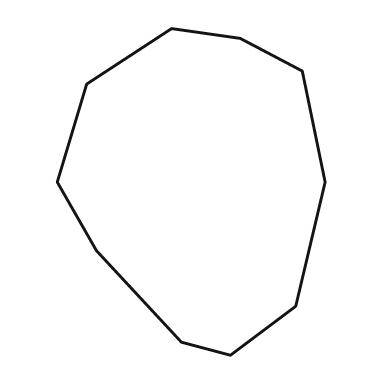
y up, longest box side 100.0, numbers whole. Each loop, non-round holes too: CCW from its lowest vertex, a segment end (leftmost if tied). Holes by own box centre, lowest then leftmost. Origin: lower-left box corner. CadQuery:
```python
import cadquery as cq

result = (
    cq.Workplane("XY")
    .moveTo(53.0, 0.0)
    .lineTo(73.0, 15.0)
    .lineTo(82.0, 53.0)
    .lineTo(75.0, 87.0)
    .lineTo(56.0, 97.0)
    .lineTo(35.0, 100.0)
    .lineTo(9.0, 83.0)
    .lineTo(0.0, 53.0)
    .lineTo(12.0, 32.0)
    .lineTo(38.0, 4.0)
    .close()
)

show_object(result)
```